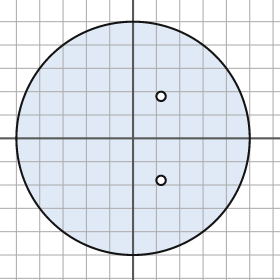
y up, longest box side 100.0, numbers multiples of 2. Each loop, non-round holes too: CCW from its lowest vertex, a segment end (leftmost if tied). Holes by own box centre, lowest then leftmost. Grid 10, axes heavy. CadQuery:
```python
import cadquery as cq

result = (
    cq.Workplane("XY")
    .moveTo(0.0, 0.0)
    .circle(50.0)
    .moveTo(12.0, -18.0)
    .circle(2.0)
    .moveTo(12.0, 18.0)
    .circle(2.0)
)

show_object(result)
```